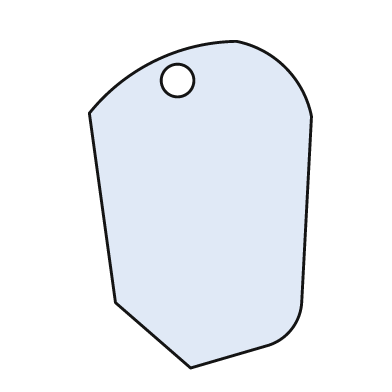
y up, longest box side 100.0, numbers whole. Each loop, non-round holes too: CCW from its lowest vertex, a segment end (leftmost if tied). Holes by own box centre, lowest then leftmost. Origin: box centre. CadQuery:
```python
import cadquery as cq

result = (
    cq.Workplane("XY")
    .moveTo(-3.0, -50.0)
    .lineTo(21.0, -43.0)
    .threePointArc((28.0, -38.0), (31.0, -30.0))
    .lineTo(34.0, 27.0)
    .threePointArc((26.0, 42.0), (11.0, 50.0))
    .threePointArc((-14.0, 44.0), (-34.0, 28.0))
    .lineTo(-26.0, -30.0)
    .close()
    .moveTo(-7.0, 38.0)
    .circle(5.0)
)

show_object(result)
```